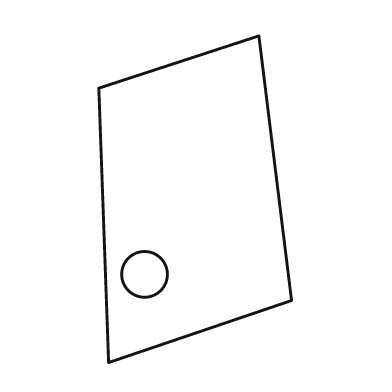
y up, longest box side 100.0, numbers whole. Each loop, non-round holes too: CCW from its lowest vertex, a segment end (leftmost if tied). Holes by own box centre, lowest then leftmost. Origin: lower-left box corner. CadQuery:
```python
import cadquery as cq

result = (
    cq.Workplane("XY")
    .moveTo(3.0, 0.0)
    .lineTo(59.0, 19.0)
    .lineTo(49.0, 100.0)
    .lineTo(0.0, 84.0)
    .close()
    .moveTo(14.0, 27.0)
    .circle(7.0)
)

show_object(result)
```